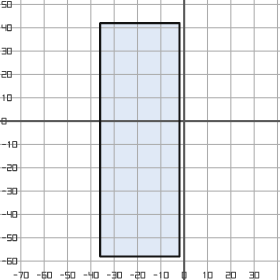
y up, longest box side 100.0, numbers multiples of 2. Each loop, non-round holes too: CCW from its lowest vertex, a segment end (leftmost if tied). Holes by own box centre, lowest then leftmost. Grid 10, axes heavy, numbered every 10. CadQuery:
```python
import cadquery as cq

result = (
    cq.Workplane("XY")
    .moveTo(-36.0, -58.0)
    .lineTo(-2.0, -58.0)
    .lineTo(-2.0, 42.0)
    .lineTo(-36.0, 42.0)
    .close()
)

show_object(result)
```